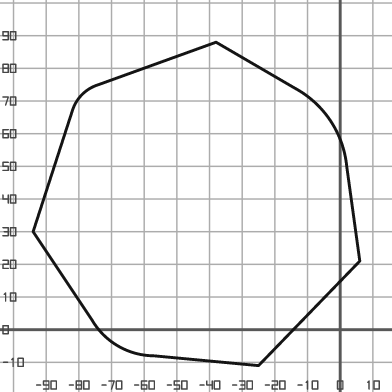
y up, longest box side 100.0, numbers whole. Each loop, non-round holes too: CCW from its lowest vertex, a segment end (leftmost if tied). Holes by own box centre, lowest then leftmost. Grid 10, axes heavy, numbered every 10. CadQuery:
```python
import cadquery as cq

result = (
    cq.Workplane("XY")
    .moveTo(-25.0, -11.0)
    .lineTo(6.0, 21.0)
    .lineTo(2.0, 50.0)
    .threePointArc((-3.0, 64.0), (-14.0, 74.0))
    .lineTo(-38.0, 88.0)
    .lineTo(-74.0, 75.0)
    .threePointArc((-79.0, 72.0), (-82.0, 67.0))
    .lineTo(-94.0, 30.0)
    .lineTo(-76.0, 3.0)
    .threePointArc((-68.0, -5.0), (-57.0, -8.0))
    .close()
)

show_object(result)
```